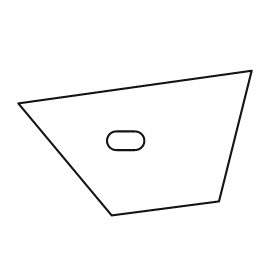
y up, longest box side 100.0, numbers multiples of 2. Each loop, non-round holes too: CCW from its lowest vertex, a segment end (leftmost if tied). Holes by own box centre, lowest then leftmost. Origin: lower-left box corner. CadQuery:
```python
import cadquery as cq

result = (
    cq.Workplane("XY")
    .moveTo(40.0, 0.0)
    .lineTo(86.0, 6.0)
    .lineTo(100.0, 62.0)
    .lineTo(0.0, 48.0)
    .close()
    .moveTo(42.0, 28.0)
    .lineTo(50.0, 28.0)
    .threePointArc((54.0, 32.0), (50.0, 36.0))
    .lineTo(42.0, 36.0)
    .threePointArc((38.0, 32.0), (42.0, 28.0))
    .close()
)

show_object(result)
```